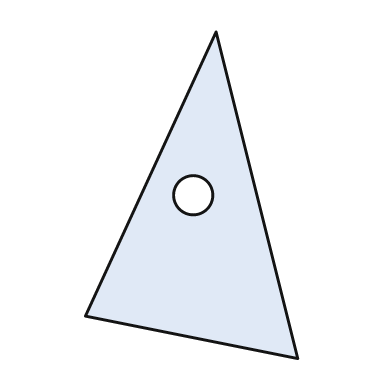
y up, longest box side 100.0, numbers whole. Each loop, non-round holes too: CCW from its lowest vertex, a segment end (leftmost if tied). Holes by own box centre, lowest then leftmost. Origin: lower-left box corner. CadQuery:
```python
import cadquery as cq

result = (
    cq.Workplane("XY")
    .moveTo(65.0, 0.0)
    .lineTo(40.0, 100.0)
    .lineTo(0.0, 13.0)
    .close()
    .moveTo(33.0, 50.0)
    .circle(6.0)
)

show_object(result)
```